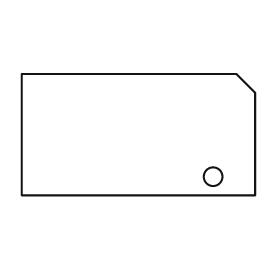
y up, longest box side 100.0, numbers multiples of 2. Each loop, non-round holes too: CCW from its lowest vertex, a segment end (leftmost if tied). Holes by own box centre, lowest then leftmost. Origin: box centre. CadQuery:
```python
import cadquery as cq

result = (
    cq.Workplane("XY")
    .moveTo(-50.0, -26.0)
    .lineTo(50.0, -26.0)
    .lineTo(50.0, 18.0)
    .lineTo(42.0, 26.0)
    .lineTo(-50.0, 26.0)
    .close()
    .moveTo(32.0, -18.0)
    .circle(4.0)
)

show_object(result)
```